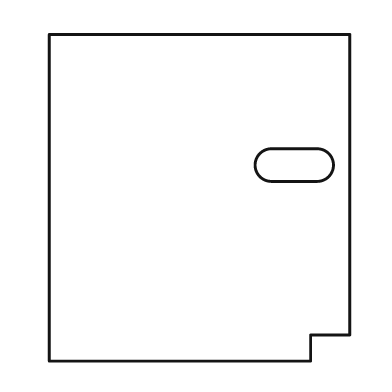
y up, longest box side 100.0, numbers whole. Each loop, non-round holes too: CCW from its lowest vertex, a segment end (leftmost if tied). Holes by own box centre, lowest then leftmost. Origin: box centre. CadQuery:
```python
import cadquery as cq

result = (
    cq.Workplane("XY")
    .moveTo(-46.0, -50.0)
    .lineTo(34.0, -50.0)
    .lineTo(34.0, -42.0)
    .lineTo(46.0, -42.0)
    .lineTo(46.0, 50.0)
    .lineTo(-46.0, 50.0)
    .close()
    .moveTo(22.0, 5.0)
    .lineTo(36.0, 5.0)
    .threePointArc((41.0, 10.0), (36.0, 15.0))
    .lineTo(22.0, 15.0)
    .threePointArc((17.0, 10.0), (22.0, 5.0))
    .close()
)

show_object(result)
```